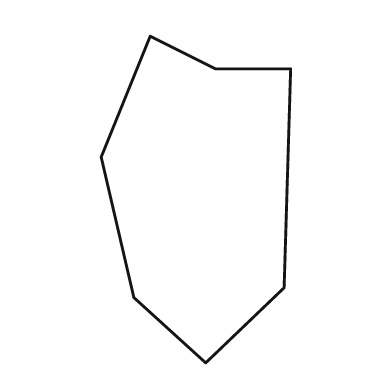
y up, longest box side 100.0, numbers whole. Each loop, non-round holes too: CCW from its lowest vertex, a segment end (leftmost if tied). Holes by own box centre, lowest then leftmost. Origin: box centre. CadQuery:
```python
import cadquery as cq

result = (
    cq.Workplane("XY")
    .moveTo(3.0, -50.0)
    .lineTo(27.0, -27.0)
    .lineTo(29.0, 40.0)
    .lineTo(6.0, 40.0)
    .lineTo(-14.0, 50.0)
    .lineTo(-29.0, 13.0)
    .lineTo(-19.0, -30.0)
    .close()
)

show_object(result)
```